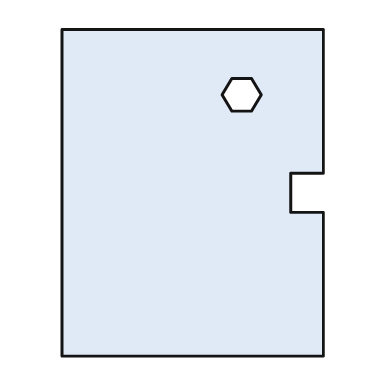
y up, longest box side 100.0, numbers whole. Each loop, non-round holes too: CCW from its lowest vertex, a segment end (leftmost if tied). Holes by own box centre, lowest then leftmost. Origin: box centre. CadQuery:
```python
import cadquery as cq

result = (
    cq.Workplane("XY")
    .moveTo(-40.0, -50.0)
    .lineTo(40.0, -50.0)
    .lineTo(40.0, -6.0)
    .lineTo(30.0, -6.0)
    .lineTo(30.0, 6.0)
    .lineTo(40.0, 6.0)
    .lineTo(40.0, 50.0)
    .lineTo(-40.0, 50.0)
    .close()
    .moveTo(12.0, 25.0)
    .lineTo(18.0, 25.0)
    .lineTo(21.0, 30.0)
    .lineTo(18.0, 35.0)
    .lineTo(12.0, 35.0)
    .lineTo(9.0, 30.0)
    .close()
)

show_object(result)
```